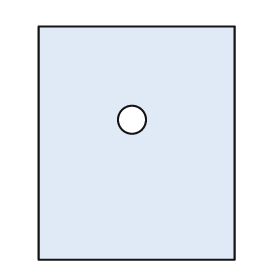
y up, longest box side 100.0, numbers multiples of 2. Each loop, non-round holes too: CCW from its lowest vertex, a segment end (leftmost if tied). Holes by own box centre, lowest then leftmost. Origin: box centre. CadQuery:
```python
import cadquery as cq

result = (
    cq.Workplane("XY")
    .moveTo(-42.0, -50.0)
    .lineTo(42.0, -50.0)
    .lineTo(42.0, 50.0)
    .lineTo(-42.0, 50.0)
    .close()
    .moveTo(-2.0, 10.0)
    .circle(6.0)
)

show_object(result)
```